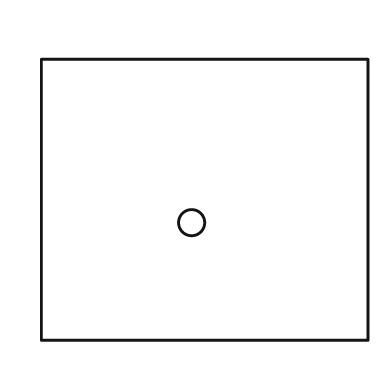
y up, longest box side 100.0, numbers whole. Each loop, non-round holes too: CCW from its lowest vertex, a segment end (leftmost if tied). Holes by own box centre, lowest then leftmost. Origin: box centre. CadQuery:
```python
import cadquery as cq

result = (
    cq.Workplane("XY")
    .moveTo(-50.0, -43.0)
    .lineTo(50.0, -43.0)
    .lineTo(50.0, 43.0)
    .lineTo(-50.0, 43.0)
    .close()
    .moveTo(-4.0, -7.0)
    .circle(4.0)
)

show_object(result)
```